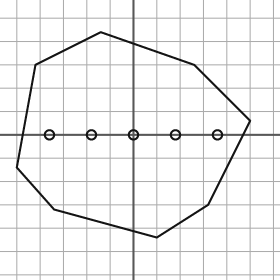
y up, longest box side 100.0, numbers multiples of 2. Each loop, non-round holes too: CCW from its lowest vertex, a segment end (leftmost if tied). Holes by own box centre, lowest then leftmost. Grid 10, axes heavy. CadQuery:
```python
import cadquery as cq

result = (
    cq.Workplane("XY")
    .moveTo(10.0, -44.0)
    .lineTo(32.0, -30.0)
    .lineTo(50.0, 6.0)
    .lineTo(26.0, 30.0)
    .lineTo(-14.0, 44.0)
    .lineTo(-42.0, 30.0)
    .lineTo(-50.0, -14.0)
    .lineTo(-34.0, -32.0)
    .close()
    .moveTo(-36.0, 0.0)
    .circle(2.0)
    .moveTo(-18.0, 0.0)
    .circle(2.0)
    .moveTo(0.0, 0.0)
    .circle(2.0)
    .moveTo(18.0, 0.0)
    .circle(2.0)
    .moveTo(36.0, 0.0)
    .circle(2.0)
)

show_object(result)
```